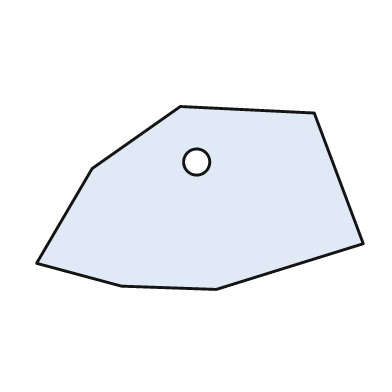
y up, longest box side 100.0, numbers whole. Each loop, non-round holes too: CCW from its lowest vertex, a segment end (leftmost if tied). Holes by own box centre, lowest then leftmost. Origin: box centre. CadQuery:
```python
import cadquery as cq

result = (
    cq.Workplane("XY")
    .moveTo(5.0, -28.0)
    .lineTo(50.0, -14.0)
    .lineTo(35.0, 26.0)
    .lineTo(-6.0, 28.0)
    .lineTo(-33.0, 9.0)
    .lineTo(-50.0, -20.0)
    .lineTo(-24.0, -27.0)
    .close()
    .moveTo(-1.0, 11.0)
    .circle(4.0)
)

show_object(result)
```